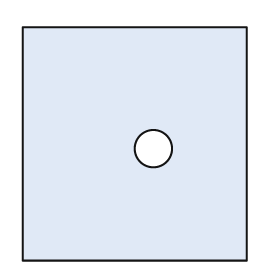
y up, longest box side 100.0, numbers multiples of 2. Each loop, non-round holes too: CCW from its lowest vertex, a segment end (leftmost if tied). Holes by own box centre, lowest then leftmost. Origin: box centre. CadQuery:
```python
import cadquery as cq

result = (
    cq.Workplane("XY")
    .moveTo(-48.0, -50.0)
    .lineTo(48.0, -50.0)
    .lineTo(48.0, 50.0)
    .lineTo(-48.0, 50.0)
    .close()
    .moveTo(8.0, -2.0)
    .circle(8.0)
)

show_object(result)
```